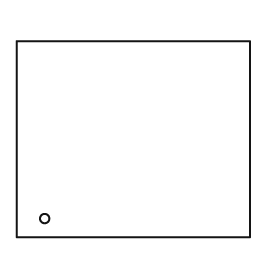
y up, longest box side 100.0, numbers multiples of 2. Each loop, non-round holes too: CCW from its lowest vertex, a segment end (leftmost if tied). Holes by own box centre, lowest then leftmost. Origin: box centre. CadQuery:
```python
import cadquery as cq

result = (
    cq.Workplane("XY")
    .moveTo(-50.0, -42.0)
    .lineTo(50.0, -42.0)
    .lineTo(50.0, 42.0)
    .lineTo(-50.0, 42.0)
    .close()
    .moveTo(-38.0, -34.0)
    .circle(2.0)
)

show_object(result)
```